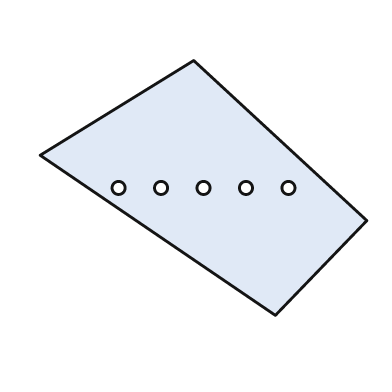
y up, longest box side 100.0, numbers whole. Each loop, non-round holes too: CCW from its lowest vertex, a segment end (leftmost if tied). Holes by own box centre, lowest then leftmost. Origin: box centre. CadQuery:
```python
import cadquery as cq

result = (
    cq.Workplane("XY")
    .moveTo(22.0, -39.0)
    .lineTo(50.0, -10.0)
    .lineTo(-3.0, 39.0)
    .lineTo(-50.0, 10.0)
    .close()
    .moveTo(-26.0, 0.0)
    .circle(2.0)
    .moveTo(-13.0, 0.0)
    .circle(2.0)
    .moveTo(0.0, 0.0)
    .circle(2.0)
    .moveTo(13.0, 0.0)
    .circle(2.0)
    .moveTo(26.0, 0.0)
    .circle(2.0)
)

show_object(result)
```